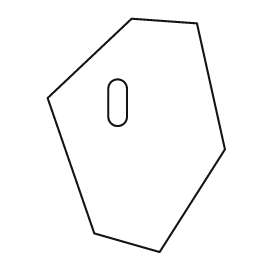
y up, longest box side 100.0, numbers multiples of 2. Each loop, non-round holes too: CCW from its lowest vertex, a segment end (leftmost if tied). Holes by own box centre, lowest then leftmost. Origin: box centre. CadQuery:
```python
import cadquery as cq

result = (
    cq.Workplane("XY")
    .moveTo(10.0, -50.0)
    .lineTo(38.0, -6.0)
    .lineTo(26.0, 48.0)
    .lineTo(-2.0, 50.0)
    .lineTo(-38.0, 16.0)
    .lineTo(-18.0, -42.0)
    .close()
    .moveTo(-12.0, 8.0)
    .threePointArc((-8.0, 4.0), (-4.0, 8.0))
    .lineTo(-4.0, 20.0)
    .threePointArc((-8.0, 24.0), (-12.0, 20.0))
    .close()
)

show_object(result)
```